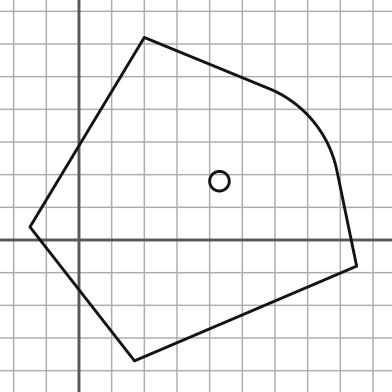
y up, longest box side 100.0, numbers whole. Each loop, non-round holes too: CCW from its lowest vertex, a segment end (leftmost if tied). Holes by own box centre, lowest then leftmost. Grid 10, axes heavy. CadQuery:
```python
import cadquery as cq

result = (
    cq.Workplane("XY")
    .moveTo(17.0, -37.0)
    .lineTo(85.0, -8.0)
    .lineTo(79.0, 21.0)
    .threePointArc((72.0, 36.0), (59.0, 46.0))
    .lineTo(20.0, 62.0)
    .lineTo(-15.0, 4.0)
    .close()
    .moveTo(43.0, 18.0)
    .circle(3.0)
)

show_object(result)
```